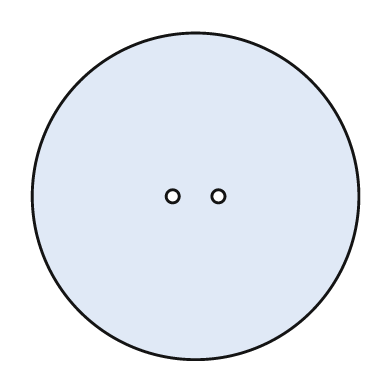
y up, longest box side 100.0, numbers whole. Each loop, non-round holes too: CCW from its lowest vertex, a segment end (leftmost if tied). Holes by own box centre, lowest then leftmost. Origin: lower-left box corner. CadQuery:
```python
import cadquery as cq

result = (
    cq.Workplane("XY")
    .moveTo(50.0, 50.0)
    .circle(50.0)
    .moveTo(43.0, 50.0)
    .circle(2.0)
    .moveTo(57.0, 50.0)
    .circle(2.0)
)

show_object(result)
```